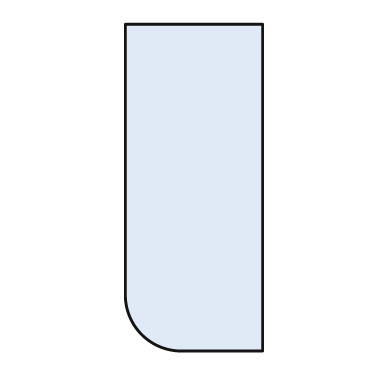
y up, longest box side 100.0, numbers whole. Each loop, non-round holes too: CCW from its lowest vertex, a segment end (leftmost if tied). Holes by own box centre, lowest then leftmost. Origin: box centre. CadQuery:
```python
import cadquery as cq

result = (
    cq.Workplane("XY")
    .moveTo(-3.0, -50.0)
    .lineTo(21.0, -50.0)
    .lineTo(21.0, 50.0)
    .lineTo(-21.0, 50.0)
    .lineTo(-21.0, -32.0)
    .threePointArc((-16.0, -45.0), (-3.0, -50.0))
    .close()
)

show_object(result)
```